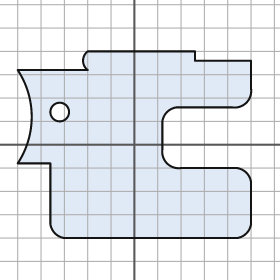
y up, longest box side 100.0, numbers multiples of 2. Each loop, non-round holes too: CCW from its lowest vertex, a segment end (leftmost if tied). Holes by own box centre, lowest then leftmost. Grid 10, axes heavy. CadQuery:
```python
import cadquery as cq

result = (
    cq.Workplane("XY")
    .moveTo(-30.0, -40.0)
    .lineTo(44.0, -40.0)
    .threePointArc((48.0, -38.0), (50.0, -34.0))
    .lineTo(50.0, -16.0)
    .threePointArc((48.0, -12.0), (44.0, -10.0))
    .lineTo(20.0, -10.0)
    .threePointArc((14.0, -8.0), (12.0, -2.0))
    .lineTo(12.0, 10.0)
    .threePointArc((14.0, 14.0), (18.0, 16.0))
    .lineTo(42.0, 16.0)
    .threePointArc((48.0, 18.0), (50.0, 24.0))
    .lineTo(50.0, 36.0)
    .lineTo(26.0, 36.0)
    .lineTo(26.0, 40.0)
    .lineTo(-20.0, 40.0)
    .threePointArc((-22.0, 36.0), (-20.0, 32.0))
    .lineTo(-50.0, 32.0)
    .threePointArc((-44.0, 12.0), (-50.0, -8.0))
    .lineTo(-36.0, -8.0)
    .lineTo(-36.0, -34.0)
    .threePointArc((-34.0, -38.0), (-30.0, -40.0))
    .close()
    .moveTo(-32.0, 14.0)
    .circle(4.0)
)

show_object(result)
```